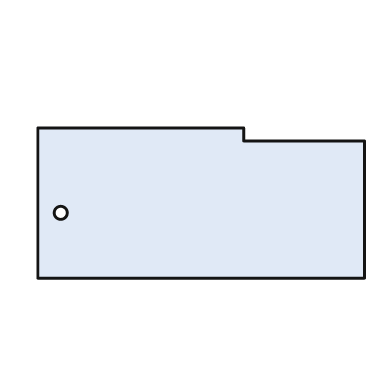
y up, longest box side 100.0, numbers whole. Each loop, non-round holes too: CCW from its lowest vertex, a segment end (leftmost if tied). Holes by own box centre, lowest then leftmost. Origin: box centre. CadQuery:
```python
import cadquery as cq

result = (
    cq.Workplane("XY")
    .moveTo(-50.0, -23.0)
    .lineTo(50.0, -23.0)
    .lineTo(50.0, 19.0)
    .lineTo(13.0, 19.0)
    .lineTo(13.0, 23.0)
    .lineTo(-50.0, 23.0)
    .close()
    .moveTo(-43.0, -3.0)
    .circle(2.0)
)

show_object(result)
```